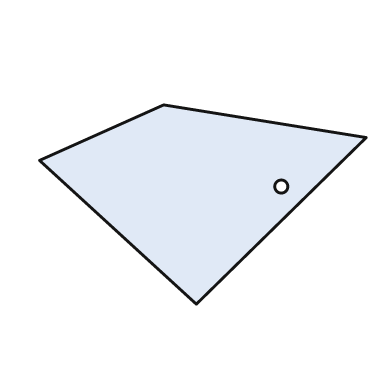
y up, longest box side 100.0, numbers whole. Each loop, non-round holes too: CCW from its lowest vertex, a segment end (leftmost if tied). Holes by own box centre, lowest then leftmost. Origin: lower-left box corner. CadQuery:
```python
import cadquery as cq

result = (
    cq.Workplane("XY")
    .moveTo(48.0, 0.0)
    .lineTo(100.0, 51.0)
    .lineTo(38.0, 61.0)
    .lineTo(0.0, 44.0)
    .close()
    .moveTo(74.0, 36.0)
    .circle(2.0)
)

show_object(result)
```